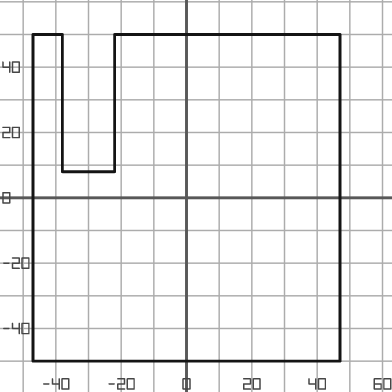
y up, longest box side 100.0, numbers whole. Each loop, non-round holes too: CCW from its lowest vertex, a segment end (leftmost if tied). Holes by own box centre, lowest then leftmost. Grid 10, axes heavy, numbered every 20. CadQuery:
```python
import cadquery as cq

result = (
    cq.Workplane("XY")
    .moveTo(-47.0, -50.0)
    .lineTo(47.0, -50.0)
    .lineTo(47.0, 50.0)
    .lineTo(-22.0, 50.0)
    .lineTo(-22.0, 8.0)
    .lineTo(-38.0, 8.0)
    .lineTo(-38.0, 50.0)
    .lineTo(-47.0, 50.0)
    .close()
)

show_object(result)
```